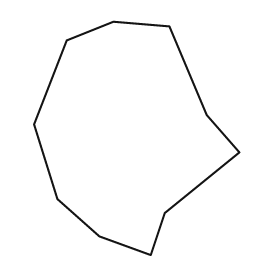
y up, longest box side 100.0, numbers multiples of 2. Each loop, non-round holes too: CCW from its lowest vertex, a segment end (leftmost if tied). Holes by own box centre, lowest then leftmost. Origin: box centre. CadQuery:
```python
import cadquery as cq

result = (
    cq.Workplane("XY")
    .moveTo(6.0, -50.0)
    .lineTo(12.0, -32.0)
    .lineTo(44.0, -6.0)
    .lineTo(30.0, 10.0)
    .lineTo(14.0, 48.0)
    .lineTo(-10.0, 50.0)
    .lineTo(-30.0, 42.0)
    .lineTo(-44.0, 6.0)
    .lineTo(-34.0, -26.0)
    .lineTo(-16.0, -42.0)
    .close()
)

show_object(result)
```